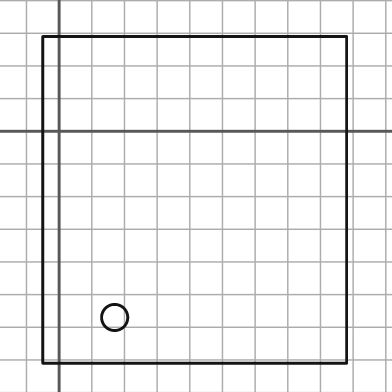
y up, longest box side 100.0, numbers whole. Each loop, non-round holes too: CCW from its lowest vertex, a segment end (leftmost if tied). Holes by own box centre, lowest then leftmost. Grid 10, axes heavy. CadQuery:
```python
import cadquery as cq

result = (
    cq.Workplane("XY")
    .moveTo(-5.0, -71.0)
    .lineTo(88.0, -71.0)
    .lineTo(88.0, 29.0)
    .lineTo(-5.0, 29.0)
    .close()
    .moveTo(17.0, -57.0)
    .circle(4.0)
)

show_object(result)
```